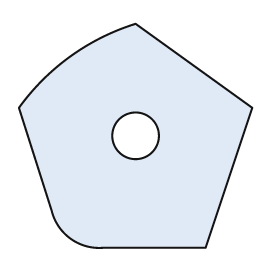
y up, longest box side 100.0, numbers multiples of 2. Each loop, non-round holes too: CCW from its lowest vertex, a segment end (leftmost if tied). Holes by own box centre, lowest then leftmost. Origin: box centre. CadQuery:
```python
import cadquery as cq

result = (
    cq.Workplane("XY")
    .moveTo(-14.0, -48.0)
    .lineTo(30.0, -48.0)
    .lineTo(50.0, 12.0)
    .lineTo(0.0, 48.0)
    .threePointArc((-28.0, 34.0), (-50.0, 12.0))
    .lineTo(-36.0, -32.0)
    .threePointArc((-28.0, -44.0), (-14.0, -48.0))
    .close()
    .moveTo(0.0, 0.0)
    .circle(10.0)
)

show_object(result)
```